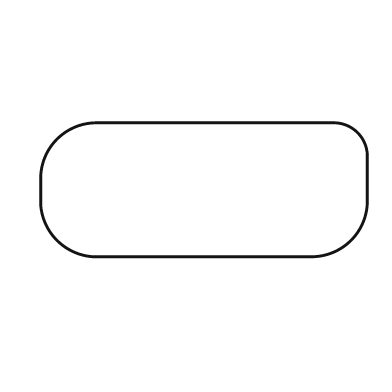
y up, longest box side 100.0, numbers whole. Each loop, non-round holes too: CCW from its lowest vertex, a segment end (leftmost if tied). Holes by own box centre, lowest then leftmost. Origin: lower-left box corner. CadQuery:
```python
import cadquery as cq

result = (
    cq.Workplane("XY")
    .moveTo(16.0, 0.0)
    .lineTo(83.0, 0.0)
    .threePointArc((95.0, 5.0), (100.0, 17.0))
    .lineTo(100.0, 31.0)
    .threePointArc((97.0, 38.0), (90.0, 41.0))
    .lineTo(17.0, 41.0)
    .threePointArc((5.0, 36.0), (0.0, 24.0))
    .lineTo(0.0, 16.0)
    .threePointArc((5.0, 5.0), (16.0, 0.0))
    .close()
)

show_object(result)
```